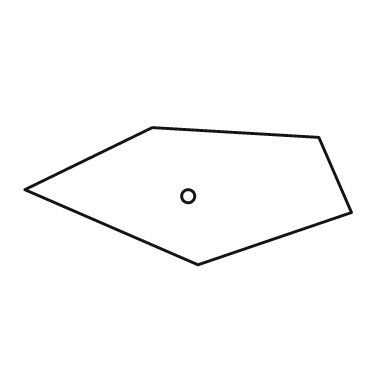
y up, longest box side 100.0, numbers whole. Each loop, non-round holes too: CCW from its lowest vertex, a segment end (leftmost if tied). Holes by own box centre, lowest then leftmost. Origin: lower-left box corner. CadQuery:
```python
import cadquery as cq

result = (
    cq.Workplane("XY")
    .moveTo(53.0, 0.0)
    .lineTo(100.0, 16.0)
    .lineTo(90.0, 39.0)
    .lineTo(39.0, 42.0)
    .lineTo(0.0, 23.0)
    .close()
    .moveTo(50.0, 21.0)
    .circle(2.0)
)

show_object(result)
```